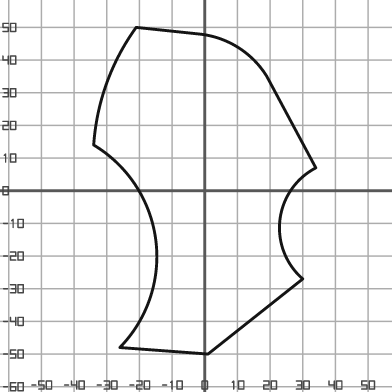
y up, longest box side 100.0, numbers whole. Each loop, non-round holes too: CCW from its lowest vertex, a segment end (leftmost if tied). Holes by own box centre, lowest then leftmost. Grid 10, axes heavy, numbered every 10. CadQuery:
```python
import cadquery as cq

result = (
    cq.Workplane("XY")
    .moveTo(1.0, -50.0)
    .lineTo(30.0, -27.0)
    .threePointArc((23.0, -9.0), (34.0, 7.0))
    .lineTo(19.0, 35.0)
    .threePointArc((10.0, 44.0), (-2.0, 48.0))
    .lineTo(-21.0, 50.0)
    .threePointArc((-30.0, 33.0), (-34.0, 14.0))
    .threePointArc((-15.0, -15.0), (-26.0, -48.0))
    .close()
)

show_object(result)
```